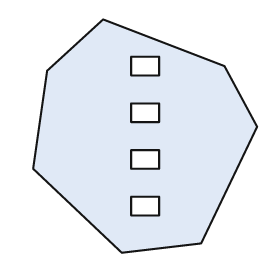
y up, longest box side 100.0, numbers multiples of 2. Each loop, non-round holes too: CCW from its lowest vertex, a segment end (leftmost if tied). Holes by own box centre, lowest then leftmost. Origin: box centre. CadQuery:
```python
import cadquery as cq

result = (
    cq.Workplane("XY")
    .moveTo(-10.0, -50.0)
    .lineTo(24.0, -46.0)
    .lineTo(48.0, 4.0)
    .lineTo(34.0, 30.0)
    .lineTo(-18.0, 50.0)
    .lineTo(-42.0, 28.0)
    .lineTo(-48.0, -14.0)
    .close()
    .moveTo(-6.0, -34.0)
    .lineTo(6.0, -34.0)
    .lineTo(6.0, -26.0)
    .lineTo(-6.0, -26.0)
    .close()
    .moveTo(-6.0, -14.0)
    .lineTo(6.0, -14.0)
    .lineTo(6.0, -6.0)
    .lineTo(-6.0, -6.0)
    .close()
    .moveTo(-6.0, 6.0)
    .lineTo(6.0, 6.0)
    .lineTo(6.0, 14.0)
    .lineTo(-6.0, 14.0)
    .close()
    .moveTo(-6.0, 26.0)
    .lineTo(6.0, 26.0)
    .lineTo(6.0, 34.0)
    .lineTo(-6.0, 34.0)
    .close()
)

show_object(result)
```